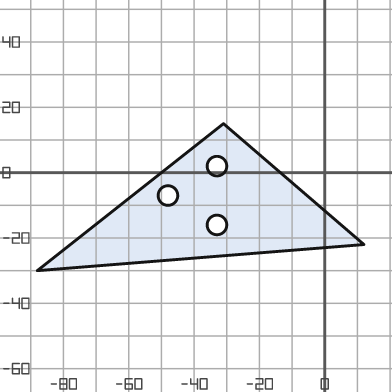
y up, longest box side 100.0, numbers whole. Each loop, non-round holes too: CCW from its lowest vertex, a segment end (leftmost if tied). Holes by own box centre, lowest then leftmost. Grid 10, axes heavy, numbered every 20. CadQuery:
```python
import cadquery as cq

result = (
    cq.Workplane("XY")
    .moveTo(-88.0, -30.0)
    .lineTo(12.0, -22.0)
    .lineTo(-31.0, 15.0)
    .close()
    .moveTo(-33.0, -16.0)
    .circle(3.0)
    .moveTo(-48.0, -7.0)
    .circle(3.0)
    .moveTo(-33.0, 2.0)
    .circle(3.0)
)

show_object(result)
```